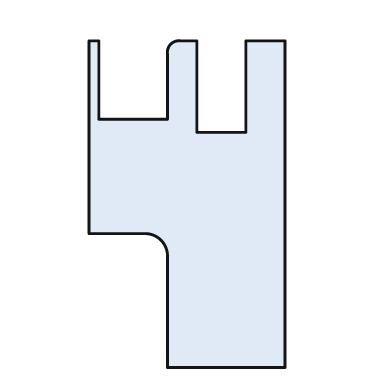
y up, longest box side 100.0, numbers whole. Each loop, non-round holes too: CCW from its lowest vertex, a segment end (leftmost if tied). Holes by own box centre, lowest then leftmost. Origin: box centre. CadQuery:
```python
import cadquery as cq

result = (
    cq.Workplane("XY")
    .moveTo(-6.0, -50.0)
    .lineTo(30.0, -50.0)
    .lineTo(30.0, 50.0)
    .lineTo(18.0, 50.0)
    .lineTo(18.0, 22.0)
    .lineTo(3.0, 22.0)
    .lineTo(3.0, 50.0)
    .lineTo(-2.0, 50.0)
    .threePointArc((-5.0, 49.0), (-6.0, 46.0))
    .lineTo(-6.0, 26.0)
    .lineTo(-27.0, 26.0)
    .lineTo(-27.0, 50.0)
    .lineTo(-30.0, 50.0)
    .lineTo(-30.0, -9.0)
    .lineTo(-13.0, -9.0)
    .threePointArc((-8.0, -11.0), (-6.0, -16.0))
    .close()
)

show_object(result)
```